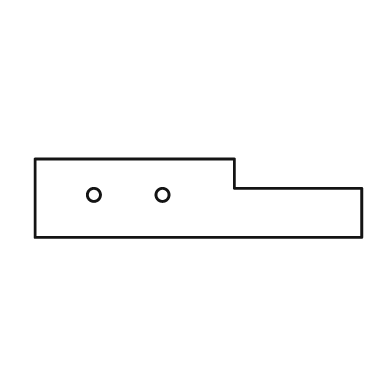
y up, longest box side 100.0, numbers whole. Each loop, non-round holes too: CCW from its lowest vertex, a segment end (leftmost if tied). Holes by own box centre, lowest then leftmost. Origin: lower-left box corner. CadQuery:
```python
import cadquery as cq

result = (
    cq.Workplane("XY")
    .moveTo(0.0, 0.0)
    .lineTo(100.0, 0.0)
    .lineTo(100.0, 15.0)
    .lineTo(61.0, 15.0)
    .lineTo(61.0, 24.0)
    .lineTo(0.0, 24.0)
    .close()
    .moveTo(18.0, 13.0)
    .circle(2.0)
    .moveTo(39.0, 13.0)
    .circle(2.0)
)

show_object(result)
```